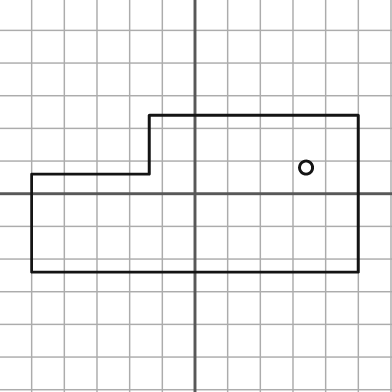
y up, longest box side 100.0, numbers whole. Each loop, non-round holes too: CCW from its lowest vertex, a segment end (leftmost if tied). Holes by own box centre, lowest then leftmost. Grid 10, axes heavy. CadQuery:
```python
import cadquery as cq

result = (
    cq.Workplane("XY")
    .moveTo(-50.0, -24.0)
    .lineTo(50.0, -24.0)
    .lineTo(50.0, 24.0)
    .lineTo(-14.0, 24.0)
    .lineTo(-14.0, 6.0)
    .lineTo(-50.0, 6.0)
    .close()
    .moveTo(34.0, 8.0)
    .circle(2.0)
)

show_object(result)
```